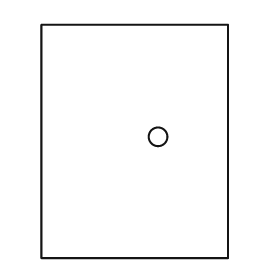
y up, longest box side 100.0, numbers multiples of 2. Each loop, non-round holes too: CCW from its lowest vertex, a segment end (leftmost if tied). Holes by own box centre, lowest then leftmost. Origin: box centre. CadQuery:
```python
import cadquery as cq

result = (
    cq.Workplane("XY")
    .moveTo(-40.0, -50.0)
    .lineTo(40.0, -50.0)
    .lineTo(40.0, 50.0)
    .lineTo(-40.0, 50.0)
    .close()
    .moveTo(10.0, 2.0)
    .circle(4.0)
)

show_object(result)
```